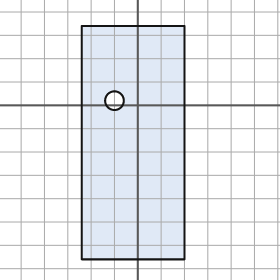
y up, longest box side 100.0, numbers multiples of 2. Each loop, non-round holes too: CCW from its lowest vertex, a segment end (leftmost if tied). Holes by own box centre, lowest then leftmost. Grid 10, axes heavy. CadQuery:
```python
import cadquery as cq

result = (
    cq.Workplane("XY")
    .moveTo(-24.0, -66.0)
    .lineTo(20.0, -66.0)
    .lineTo(20.0, 34.0)
    .lineTo(-24.0, 34.0)
    .close()
    .moveTo(-10.0, 2.0)
    .circle(4.0)
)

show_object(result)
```